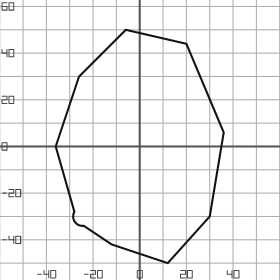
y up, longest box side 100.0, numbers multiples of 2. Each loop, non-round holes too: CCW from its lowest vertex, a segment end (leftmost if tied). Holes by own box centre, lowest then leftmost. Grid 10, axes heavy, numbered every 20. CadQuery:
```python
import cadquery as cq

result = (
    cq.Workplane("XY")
    .moveTo(12.0, -50.0)
    .lineTo(30.0, -30.0)
    .lineTo(36.0, 6.0)
    .lineTo(20.0, 44.0)
    .lineTo(-6.0, 50.0)
    .lineTo(-26.0, 30.0)
    .lineTo(-36.0, 0.0)
    .lineTo(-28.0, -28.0)
    .threePointArc((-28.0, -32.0), (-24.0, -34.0))
    .lineTo(-12.0, -42.0)
    .close()
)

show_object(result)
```